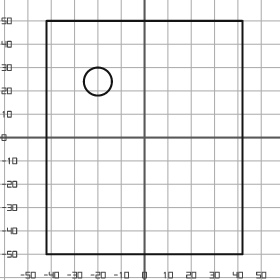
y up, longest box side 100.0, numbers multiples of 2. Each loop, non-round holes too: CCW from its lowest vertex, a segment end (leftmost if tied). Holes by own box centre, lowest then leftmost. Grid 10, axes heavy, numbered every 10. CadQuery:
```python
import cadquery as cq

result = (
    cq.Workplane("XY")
    .moveTo(-42.0, -50.0)
    .lineTo(42.0, -50.0)
    .lineTo(42.0, 50.0)
    .lineTo(-42.0, 50.0)
    .close()
    .moveTo(-20.0, 24.0)
    .circle(6.0)
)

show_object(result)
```